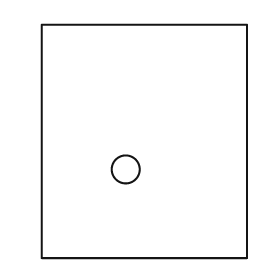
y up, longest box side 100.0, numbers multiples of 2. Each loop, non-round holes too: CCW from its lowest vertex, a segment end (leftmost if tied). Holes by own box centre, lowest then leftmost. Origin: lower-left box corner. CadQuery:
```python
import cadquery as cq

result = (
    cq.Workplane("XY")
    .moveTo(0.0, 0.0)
    .lineTo(88.0, 0.0)
    .lineTo(88.0, 100.0)
    .lineTo(0.0, 100.0)
    .close()
    .moveTo(36.0, 38.0)
    .circle(6.0)
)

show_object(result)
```